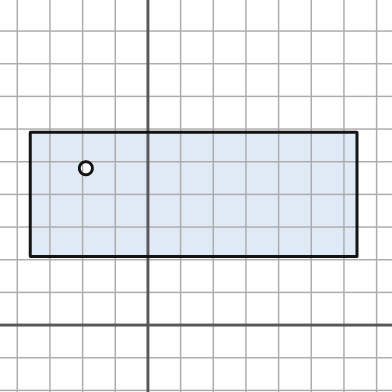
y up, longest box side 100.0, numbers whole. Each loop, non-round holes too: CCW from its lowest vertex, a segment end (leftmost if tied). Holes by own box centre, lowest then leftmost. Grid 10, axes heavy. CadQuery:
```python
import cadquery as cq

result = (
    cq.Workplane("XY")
    .moveTo(-36.0, 21.0)
    .lineTo(64.0, 21.0)
    .lineTo(64.0, 59.0)
    .lineTo(-36.0, 59.0)
    .close()
    .moveTo(-19.0, 48.0)
    .circle(2.0)
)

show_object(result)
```